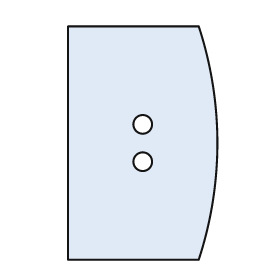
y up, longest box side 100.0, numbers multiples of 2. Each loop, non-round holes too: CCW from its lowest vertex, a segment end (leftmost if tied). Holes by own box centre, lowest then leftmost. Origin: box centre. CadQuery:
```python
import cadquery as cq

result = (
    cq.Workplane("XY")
    .moveTo(-32.0, -50.0)
    .lineTo(24.0, -50.0)
    .threePointArc((32.0, 0.0), (24.0, 50.0))
    .lineTo(-32.0, 50.0)
    .close()
    .moveTo(0.0, -8.0)
    .circle(4.0)
    .moveTo(0.0, 8.0)
    .circle(4.0)
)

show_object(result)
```